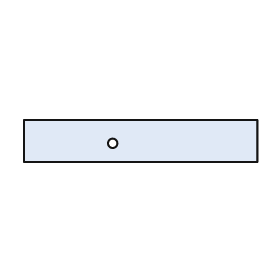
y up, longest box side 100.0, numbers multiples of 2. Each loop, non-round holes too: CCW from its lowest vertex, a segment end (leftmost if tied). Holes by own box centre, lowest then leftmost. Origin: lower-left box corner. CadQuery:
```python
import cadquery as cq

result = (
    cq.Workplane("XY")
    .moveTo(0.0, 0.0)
    .lineTo(100.0, 0.0)
    .lineTo(100.0, 18.0)
    .lineTo(0.0, 18.0)
    .close()
    .moveTo(38.0, 8.0)
    .circle(2.0)
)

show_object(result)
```